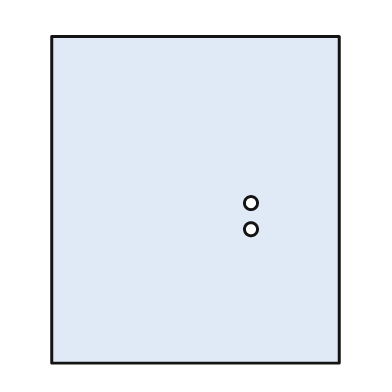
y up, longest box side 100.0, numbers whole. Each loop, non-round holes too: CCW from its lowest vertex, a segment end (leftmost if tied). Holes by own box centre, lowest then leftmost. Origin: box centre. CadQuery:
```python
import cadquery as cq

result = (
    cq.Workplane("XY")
    .moveTo(-44.0, -50.0)
    .lineTo(44.0, -50.0)
    .lineTo(44.0, 50.0)
    .lineTo(-44.0, 50.0)
    .close()
    .moveTo(17.0, -9.0)
    .circle(2.0)
    .moveTo(17.0, -1.0)
    .circle(2.0)
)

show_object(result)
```